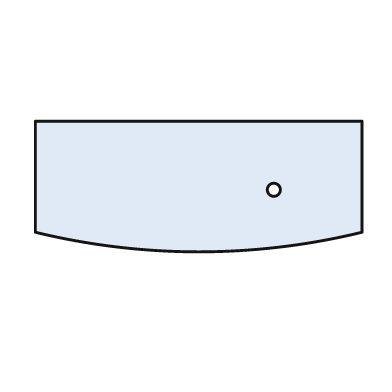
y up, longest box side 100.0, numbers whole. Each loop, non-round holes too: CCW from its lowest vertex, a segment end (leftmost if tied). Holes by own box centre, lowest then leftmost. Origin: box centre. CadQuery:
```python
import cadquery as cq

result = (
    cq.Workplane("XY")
    .moveTo(-50.0, -14.0)
    .threePointArc((0.0, -20.0), (50.0, -14.0))
    .lineTo(50.0, 20.0)
    .lineTo(-50.0, 20.0)
    .close()
    .moveTo(23.0, -1.0)
    .circle(2.0)
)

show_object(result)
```